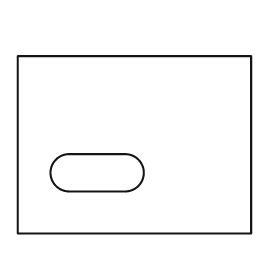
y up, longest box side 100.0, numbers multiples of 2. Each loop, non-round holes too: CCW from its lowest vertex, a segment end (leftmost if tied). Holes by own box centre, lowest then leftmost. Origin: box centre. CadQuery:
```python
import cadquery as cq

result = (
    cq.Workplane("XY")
    .moveTo(-50.0, -38.0)
    .lineTo(50.0, -38.0)
    .lineTo(50.0, 38.0)
    .lineTo(-50.0, 38.0)
    .close()
    .moveTo(-28.0, -20.0)
    .lineTo(-4.0, -20.0)
    .threePointArc((4.0, -12.0), (-4.0, -4.0))
    .lineTo(-28.0, -4.0)
    .threePointArc((-36.0, -12.0), (-28.0, -20.0))
    .close()
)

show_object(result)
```